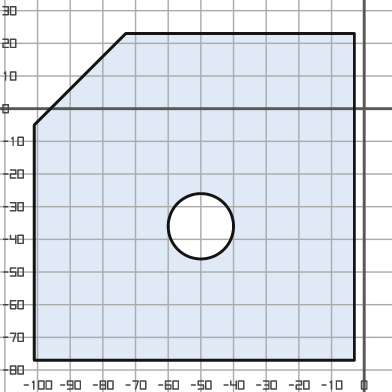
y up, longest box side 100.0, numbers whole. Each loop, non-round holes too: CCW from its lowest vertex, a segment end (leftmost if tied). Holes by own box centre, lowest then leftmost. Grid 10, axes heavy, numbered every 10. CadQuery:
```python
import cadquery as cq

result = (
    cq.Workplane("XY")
    .moveTo(-101.0, -77.0)
    .lineTo(-3.0, -77.0)
    .lineTo(-3.0, 23.0)
    .lineTo(-73.0, 23.0)
    .lineTo(-101.0, -5.0)
    .close()
    .moveTo(-50.0, -36.0)
    .circle(10.0)
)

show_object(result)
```